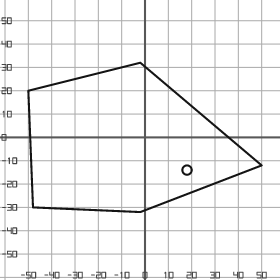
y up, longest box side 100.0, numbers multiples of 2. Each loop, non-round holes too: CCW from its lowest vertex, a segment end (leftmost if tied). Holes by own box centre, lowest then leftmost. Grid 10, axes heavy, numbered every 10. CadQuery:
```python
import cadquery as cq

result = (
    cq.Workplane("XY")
    .moveTo(-2.0, -32.0)
    .lineTo(50.0, -12.0)
    .lineTo(-2.0, 32.0)
    .lineTo(-50.0, 20.0)
    .lineTo(-48.0, -30.0)
    .close()
    .moveTo(18.0, -14.0)
    .circle(2.0)
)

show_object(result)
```